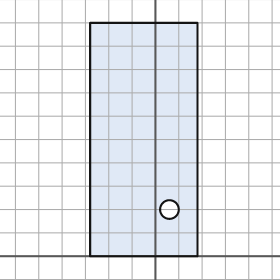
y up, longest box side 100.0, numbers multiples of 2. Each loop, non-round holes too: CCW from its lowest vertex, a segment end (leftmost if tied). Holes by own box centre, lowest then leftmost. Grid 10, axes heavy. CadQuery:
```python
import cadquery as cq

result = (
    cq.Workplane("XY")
    .moveTo(-28.0, 0.0)
    .lineTo(18.0, 0.0)
    .lineTo(18.0, 100.0)
    .lineTo(-28.0, 100.0)
    .close()
    .moveTo(6.0, 20.0)
    .circle(4.0)
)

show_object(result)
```